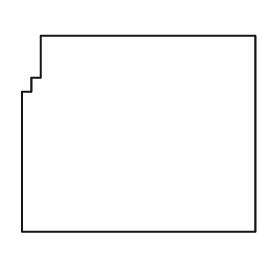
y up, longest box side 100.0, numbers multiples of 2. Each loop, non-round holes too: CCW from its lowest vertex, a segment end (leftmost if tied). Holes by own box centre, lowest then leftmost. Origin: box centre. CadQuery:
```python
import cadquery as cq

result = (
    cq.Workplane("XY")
    .moveTo(-50.0, -42.0)
    .lineTo(50.0, -42.0)
    .lineTo(50.0, 42.0)
    .lineTo(-42.0, 42.0)
    .lineTo(-42.0, 24.0)
    .lineTo(-46.0, 24.0)
    .lineTo(-46.0, 18.0)
    .lineTo(-50.0, 18.0)
    .close()
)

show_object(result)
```